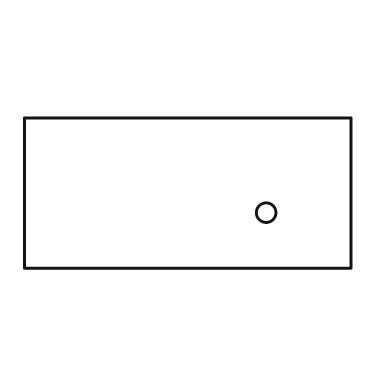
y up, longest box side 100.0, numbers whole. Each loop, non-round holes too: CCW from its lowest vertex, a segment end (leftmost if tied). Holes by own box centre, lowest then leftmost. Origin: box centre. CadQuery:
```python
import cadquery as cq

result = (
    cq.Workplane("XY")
    .moveTo(-50.0, -23.0)
    .lineTo(50.0, -23.0)
    .lineTo(50.0, 23.0)
    .lineTo(-50.0, 23.0)
    .close()
    .moveTo(24.0, -6.0)
    .circle(3.0)
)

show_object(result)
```